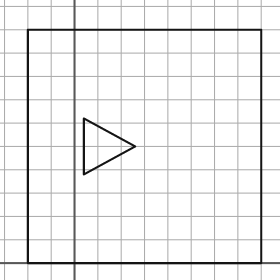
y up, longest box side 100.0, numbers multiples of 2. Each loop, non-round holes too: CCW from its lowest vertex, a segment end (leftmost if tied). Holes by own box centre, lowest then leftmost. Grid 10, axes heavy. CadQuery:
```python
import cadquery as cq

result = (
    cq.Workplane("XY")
    .moveTo(-20.0, 0.0)
    .lineTo(80.0, 0.0)
    .lineTo(80.0, 100.0)
    .lineTo(-20.0, 100.0)
    .close()
    .moveTo(4.0, 38.0)
    .lineTo(26.0, 50.0)
    .lineTo(4.0, 62.0)
    .close()
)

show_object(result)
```